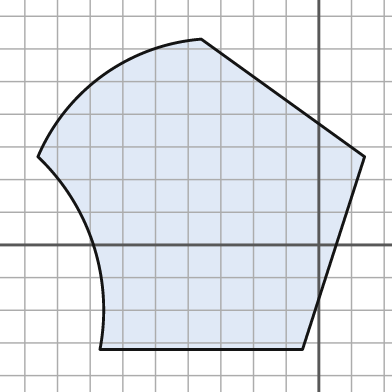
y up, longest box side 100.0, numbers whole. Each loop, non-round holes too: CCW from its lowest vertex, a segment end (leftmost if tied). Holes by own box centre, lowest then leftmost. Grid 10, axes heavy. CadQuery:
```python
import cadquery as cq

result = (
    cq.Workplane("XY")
    .moveTo(-67.0, -32.0)
    .lineTo(-5.0, -32.0)
    .lineTo(14.0, 27.0)
    .lineTo(-36.0, 63.0)
    .threePointArc((-66.0, 52.0), (-86.0, 27.0))
    .threePointArc((-69.0, 0.0), (-67.0, -32.0))
    .close()
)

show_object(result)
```